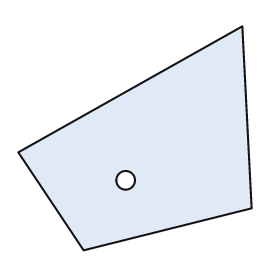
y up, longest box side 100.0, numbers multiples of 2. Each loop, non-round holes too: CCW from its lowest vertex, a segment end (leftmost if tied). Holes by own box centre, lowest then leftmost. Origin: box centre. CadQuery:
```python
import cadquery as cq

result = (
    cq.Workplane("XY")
    .moveTo(-22.0, -48.0)
    .lineTo(50.0, -30.0)
    .lineTo(46.0, 48.0)
    .lineTo(-50.0, -6.0)
    .close()
    .moveTo(-4.0, -18.0)
    .circle(4.0)
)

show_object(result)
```